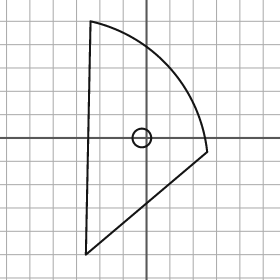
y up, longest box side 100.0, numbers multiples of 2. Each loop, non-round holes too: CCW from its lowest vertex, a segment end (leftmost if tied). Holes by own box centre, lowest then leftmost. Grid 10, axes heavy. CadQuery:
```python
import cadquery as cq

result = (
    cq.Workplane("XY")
    .moveTo(-26.0, -50.0)
    .lineTo(26.0, -6.0)
    .threePointArc((10.0, 30.0), (-24.0, 50.0))
    .close()
    .moveTo(-2.0, 0.0)
    .circle(4.0)
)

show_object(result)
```